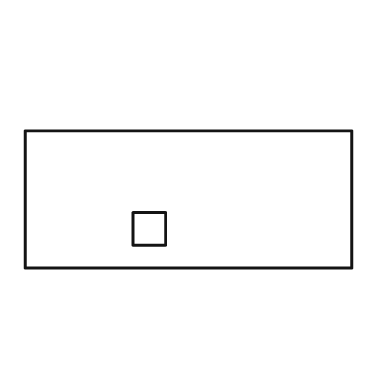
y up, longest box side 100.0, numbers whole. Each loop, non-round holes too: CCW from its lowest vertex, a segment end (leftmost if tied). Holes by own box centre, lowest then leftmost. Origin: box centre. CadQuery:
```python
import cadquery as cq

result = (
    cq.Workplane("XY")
    .moveTo(-50.0, -21.0)
    .lineTo(50.0, -21.0)
    .lineTo(50.0, 21.0)
    .lineTo(-50.0, 21.0)
    .close()
    .moveTo(-17.0, -14.0)
    .lineTo(-7.0, -14.0)
    .lineTo(-7.0, -4.0)
    .lineTo(-17.0, -4.0)
    .close()
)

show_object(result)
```